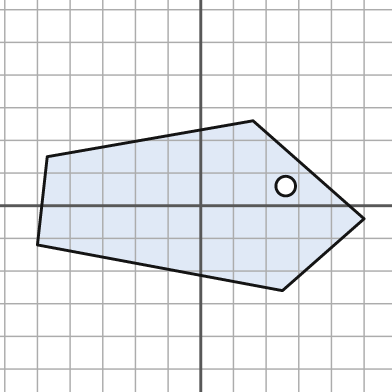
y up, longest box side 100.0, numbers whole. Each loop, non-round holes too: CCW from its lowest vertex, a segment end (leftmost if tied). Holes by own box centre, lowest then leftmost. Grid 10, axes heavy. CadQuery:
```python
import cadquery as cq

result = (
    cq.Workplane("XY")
    .moveTo(25.0, -26.0)
    .lineTo(50.0, -4.0)
    .lineTo(16.0, 26.0)
    .lineTo(-47.0, 15.0)
    .lineTo(-50.0, -12.0)
    .close()
    .moveTo(26.0, 6.0)
    .circle(3.0)
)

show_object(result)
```